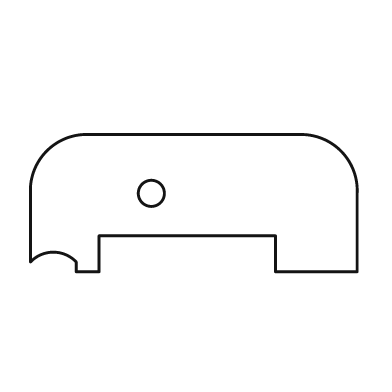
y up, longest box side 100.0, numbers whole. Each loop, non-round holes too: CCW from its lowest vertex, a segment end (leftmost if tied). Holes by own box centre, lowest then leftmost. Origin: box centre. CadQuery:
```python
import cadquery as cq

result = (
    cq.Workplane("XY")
    .moveTo(-36.0, -21.0)
    .lineTo(-29.0, -21.0)
    .lineTo(-29.0, -10.0)
    .lineTo(25.0, -10.0)
    .lineTo(25.0, -21.0)
    .lineTo(50.0, -21.0)
    .lineTo(50.0, 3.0)
    .threePointArc((45.0, 16.0), (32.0, 21.0))
    .lineTo(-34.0, 21.0)
    .threePointArc((-45.0, 16.0), (-50.0, 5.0))
    .lineTo(-50.0, -18.0)
    .threePointArc((-43.0, -15.0), (-36.0, -18.0))
    .close()
    .moveTo(-13.0, 3.0)
    .circle(4.0)
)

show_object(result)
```